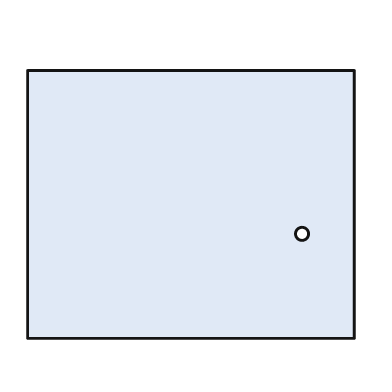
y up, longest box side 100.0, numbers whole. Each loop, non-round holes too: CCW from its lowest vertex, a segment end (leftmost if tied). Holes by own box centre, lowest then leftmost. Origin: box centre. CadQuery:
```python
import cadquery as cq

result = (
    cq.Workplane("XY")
    .moveTo(-50.0, -41.0)
    .lineTo(50.0, -41.0)
    .lineTo(50.0, 41.0)
    .lineTo(-50.0, 41.0)
    .close()
    .moveTo(34.0, -9.0)
    .circle(2.0)
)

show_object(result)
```